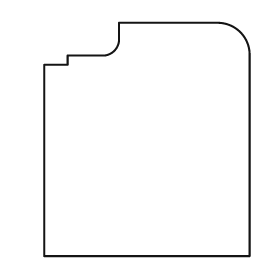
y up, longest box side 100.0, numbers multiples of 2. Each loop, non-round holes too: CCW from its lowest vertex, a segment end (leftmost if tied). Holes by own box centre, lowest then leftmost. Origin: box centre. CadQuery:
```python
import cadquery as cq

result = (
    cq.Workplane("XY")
    .moveTo(-44.0, -50.0)
    .lineTo(44.0, -50.0)
    .lineTo(44.0, 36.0)
    .threePointArc((40.0, 46.0), (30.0, 50.0))
    .lineTo(-12.0, 50.0)
    .lineTo(-12.0, 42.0)
    .threePointArc((-14.0, 38.0), (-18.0, 36.0))
    .lineTo(-34.0, 36.0)
    .lineTo(-34.0, 32.0)
    .lineTo(-44.0, 32.0)
    .close()
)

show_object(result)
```